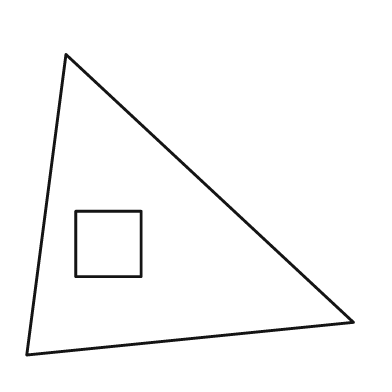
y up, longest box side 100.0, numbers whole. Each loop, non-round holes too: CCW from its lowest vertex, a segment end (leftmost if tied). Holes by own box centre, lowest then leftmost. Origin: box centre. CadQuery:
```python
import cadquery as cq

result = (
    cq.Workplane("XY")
    .moveTo(-50.0, -46.0)
    .lineTo(50.0, -36.0)
    .lineTo(-38.0, 46.0)
    .close()
    .moveTo(-35.0, -22.0)
    .lineTo(-15.0, -22.0)
    .lineTo(-15.0, -2.0)
    .lineTo(-35.0, -2.0)
    .close()
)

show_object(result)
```